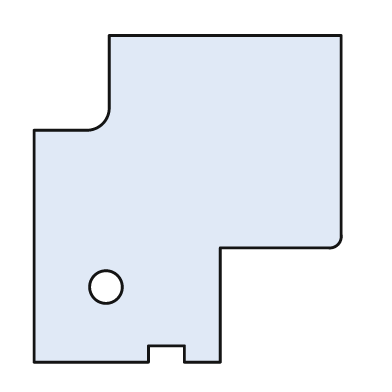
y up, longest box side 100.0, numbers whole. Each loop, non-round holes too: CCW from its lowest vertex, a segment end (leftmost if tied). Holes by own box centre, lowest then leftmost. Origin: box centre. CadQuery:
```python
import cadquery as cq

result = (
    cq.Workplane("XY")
    .moveTo(-47.0, -50.0)
    .lineTo(-12.0, -50.0)
    .lineTo(-12.0, -45.0)
    .lineTo(-1.0, -45.0)
    .lineTo(-1.0, -50.0)
    .lineTo(10.0, -50.0)
    .lineTo(10.0, -15.0)
    .lineTo(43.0, -15.0)
    .threePointArc((46.0, -14.0), (47.0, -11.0))
    .lineTo(47.0, 50.0)
    .lineTo(-24.0, 50.0)
    .lineTo(-24.0, 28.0)
    .threePointArc((-26.0, 23.0), (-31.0, 21.0))
    .lineTo(-47.0, 21.0)
    .close()
    .moveTo(-25.0, -27.0)
    .circle(5.0)
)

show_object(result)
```